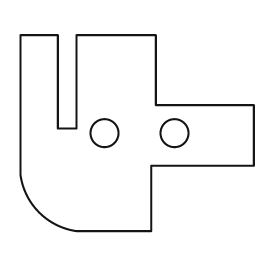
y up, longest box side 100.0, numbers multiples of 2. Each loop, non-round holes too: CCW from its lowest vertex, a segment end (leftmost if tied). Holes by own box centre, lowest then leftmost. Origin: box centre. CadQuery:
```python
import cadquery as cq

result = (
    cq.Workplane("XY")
    .moveTo(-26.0, -42.0)
    .lineTo(6.0, -42.0)
    .lineTo(6.0, -14.0)
    .lineTo(50.0, -14.0)
    .lineTo(50.0, 12.0)
    .lineTo(8.0, 12.0)
    .lineTo(8.0, 42.0)
    .lineTo(-26.0, 42.0)
    .lineTo(-26.0, 2.0)
    .lineTo(-34.0, 2.0)
    .lineTo(-34.0, 42.0)
    .lineTo(-50.0, 42.0)
    .lineTo(-50.0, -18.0)
    .threePointArc((-42.0, -34.0), (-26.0, -42.0))
    .close()
    .moveTo(-14.0, 0.0)
    .circle(6.0)
    .moveTo(16.0, 0.0)
    .circle(6.0)
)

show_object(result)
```